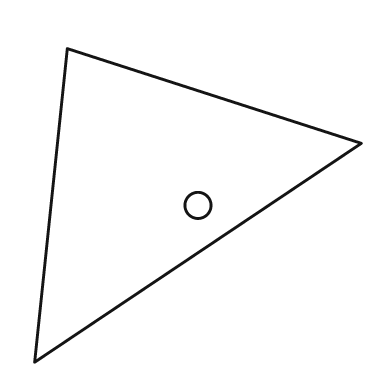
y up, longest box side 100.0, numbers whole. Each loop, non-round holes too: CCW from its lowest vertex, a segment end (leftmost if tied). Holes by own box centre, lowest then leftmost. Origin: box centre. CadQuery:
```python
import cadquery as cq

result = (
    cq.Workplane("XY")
    .moveTo(-50.0, -48.0)
    .lineTo(50.0, 19.0)
    .lineTo(-40.0, 48.0)
    .close()
    .moveTo(0.0, 0.0)
    .circle(4.0)
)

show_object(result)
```